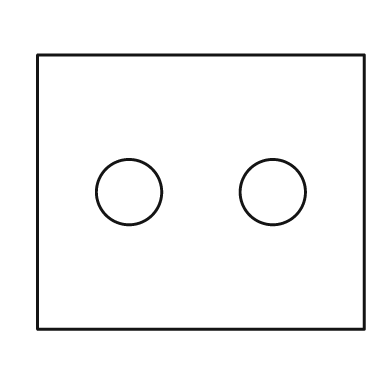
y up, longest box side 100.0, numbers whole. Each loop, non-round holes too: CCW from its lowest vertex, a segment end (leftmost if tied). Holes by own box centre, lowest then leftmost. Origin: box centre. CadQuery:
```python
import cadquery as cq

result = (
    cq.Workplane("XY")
    .moveTo(-50.0, -42.0)
    .lineTo(50.0, -42.0)
    .lineTo(50.0, 42.0)
    .lineTo(-50.0, 42.0)
    .close()
    .moveTo(-22.0, 0.0)
    .circle(10.0)
    .moveTo(22.0, 0.0)
    .circle(10.0)
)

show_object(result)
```